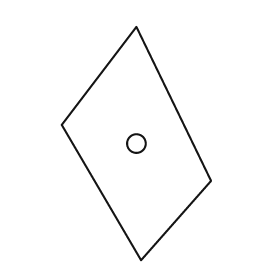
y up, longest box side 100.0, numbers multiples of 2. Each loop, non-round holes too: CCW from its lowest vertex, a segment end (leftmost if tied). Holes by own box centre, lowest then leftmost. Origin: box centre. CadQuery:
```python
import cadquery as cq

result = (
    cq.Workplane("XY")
    .moveTo(2.0, -50.0)
    .lineTo(32.0, -16.0)
    .lineTo(0.0, 50.0)
    .lineTo(-32.0, 8.0)
    .close()
    .moveTo(0.0, 0.0)
    .circle(4.0)
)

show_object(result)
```